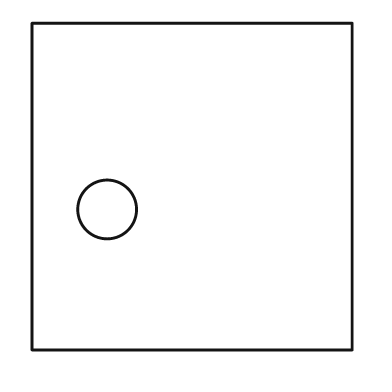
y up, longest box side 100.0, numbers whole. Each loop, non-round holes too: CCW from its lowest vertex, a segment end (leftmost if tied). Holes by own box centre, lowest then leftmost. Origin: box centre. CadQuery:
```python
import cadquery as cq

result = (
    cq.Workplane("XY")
    .moveTo(-49.0, -50.0)
    .lineTo(49.0, -50.0)
    .lineTo(49.0, 50.0)
    .lineTo(-49.0, 50.0)
    .close()
    .moveTo(-26.0, -7.0)
    .circle(9.0)
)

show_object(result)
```